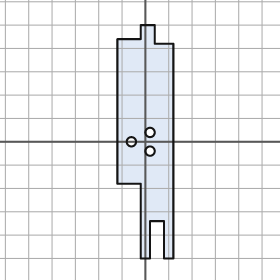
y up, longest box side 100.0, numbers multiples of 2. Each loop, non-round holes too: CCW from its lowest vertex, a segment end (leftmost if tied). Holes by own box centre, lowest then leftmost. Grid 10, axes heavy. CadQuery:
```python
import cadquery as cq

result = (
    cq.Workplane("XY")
    .moveTo(-2.0, -50.0)
    .lineTo(2.0, -50.0)
    .lineTo(2.0, -34.0)
    .lineTo(8.0, -34.0)
    .lineTo(8.0, -50.0)
    .lineTo(12.0, -50.0)
    .lineTo(12.0, 42.0)
    .lineTo(4.0, 42.0)
    .lineTo(4.0, 50.0)
    .lineTo(-2.0, 50.0)
    .lineTo(-2.0, 44.0)
    .lineTo(-12.0, 44.0)
    .lineTo(-12.0, -18.0)
    .lineTo(-2.0, -18.0)
    .close()
    .moveTo(2.0, -4.0)
    .circle(2.0)
    .moveTo(-6.0, 0.0)
    .circle(2.0)
    .moveTo(2.0, 4.0)
    .circle(2.0)
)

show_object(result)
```